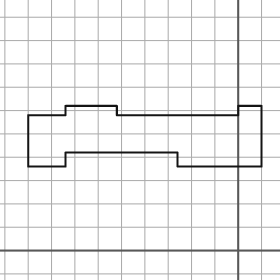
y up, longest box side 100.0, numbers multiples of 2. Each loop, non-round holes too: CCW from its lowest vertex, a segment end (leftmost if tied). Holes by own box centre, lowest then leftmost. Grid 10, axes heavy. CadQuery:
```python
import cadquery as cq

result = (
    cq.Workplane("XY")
    .moveTo(-90.0, 36.0)
    .lineTo(-74.0, 36.0)
    .lineTo(-74.0, 42.0)
    .lineTo(-26.0, 42.0)
    .lineTo(-26.0, 36.0)
    .lineTo(10.0, 36.0)
    .lineTo(10.0, 62.0)
    .lineTo(0.0, 62.0)
    .lineTo(0.0, 58.0)
    .lineTo(-52.0, 58.0)
    .lineTo(-52.0, 62.0)
    .lineTo(-74.0, 62.0)
    .lineTo(-74.0, 58.0)
    .lineTo(-90.0, 58.0)
    .close()
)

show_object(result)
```